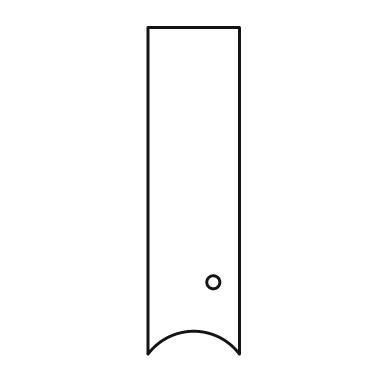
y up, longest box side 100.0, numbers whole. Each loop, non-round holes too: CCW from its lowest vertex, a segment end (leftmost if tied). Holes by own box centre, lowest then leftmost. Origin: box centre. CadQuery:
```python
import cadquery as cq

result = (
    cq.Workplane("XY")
    .moveTo(-14.0, -50.0)
    .threePointArc((0.0, -43.0), (14.0, -50.0))
    .lineTo(14.0, 50.0)
    .lineTo(-14.0, 50.0)
    .close()
    .moveTo(6.0, -28.0)
    .circle(2.0)
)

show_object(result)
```